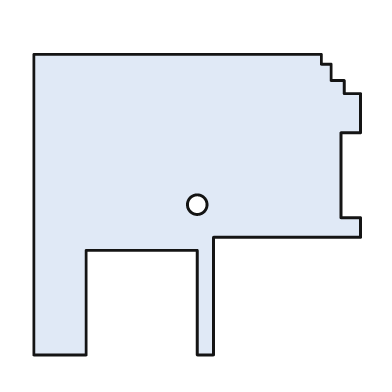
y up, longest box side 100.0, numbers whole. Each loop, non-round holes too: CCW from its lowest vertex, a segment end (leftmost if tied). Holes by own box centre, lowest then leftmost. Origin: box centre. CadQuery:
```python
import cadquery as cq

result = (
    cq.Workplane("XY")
    .moveTo(-50.0, -46.0)
    .lineTo(-34.0, -46.0)
    .lineTo(-34.0, -14.0)
    .lineTo(0.0, -14.0)
    .lineTo(0.0, -46.0)
    .lineTo(5.0, -46.0)
    .lineTo(5.0, -10.0)
    .lineTo(50.0, -10.0)
    .lineTo(50.0, -4.0)
    .lineTo(44.0, -4.0)
    .lineTo(44.0, 22.0)
    .lineTo(50.0, 22.0)
    .lineTo(50.0, 34.0)
    .lineTo(45.0, 34.0)
    .lineTo(45.0, 38.0)
    .lineTo(41.0, 38.0)
    .lineTo(41.0, 43.0)
    .lineTo(38.0, 43.0)
    .lineTo(38.0, 46.0)
    .lineTo(-50.0, 46.0)
    .close()
    .moveTo(0.0, 0.0)
    .circle(3.0)
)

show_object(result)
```